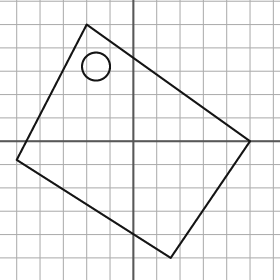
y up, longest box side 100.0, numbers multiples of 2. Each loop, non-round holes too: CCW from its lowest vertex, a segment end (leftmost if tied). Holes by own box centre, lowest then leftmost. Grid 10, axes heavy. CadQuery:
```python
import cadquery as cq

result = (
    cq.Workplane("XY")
    .moveTo(16.0, -50.0)
    .lineTo(50.0, 0.0)
    .lineTo(-20.0, 50.0)
    .lineTo(-50.0, -8.0)
    .close()
    .moveTo(-16.0, 32.0)
    .circle(6.0)
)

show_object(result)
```